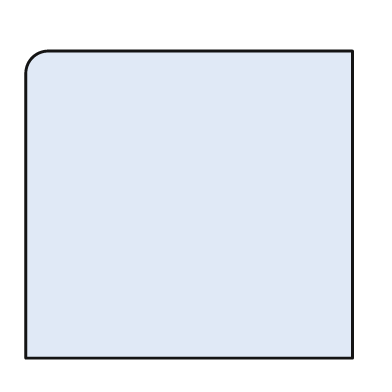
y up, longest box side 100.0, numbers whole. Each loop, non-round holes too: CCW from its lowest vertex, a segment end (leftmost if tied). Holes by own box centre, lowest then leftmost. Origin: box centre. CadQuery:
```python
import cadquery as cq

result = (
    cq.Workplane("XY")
    .moveTo(-50.0, -47.0)
    .lineTo(50.0, -47.0)
    .lineTo(50.0, 47.0)
    .lineTo(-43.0, 47.0)
    .threePointArc((-48.0, 45.0), (-50.0, 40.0))
    .close()
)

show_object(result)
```